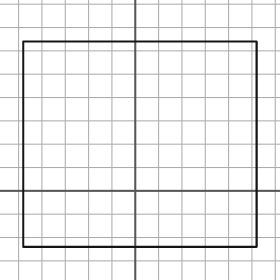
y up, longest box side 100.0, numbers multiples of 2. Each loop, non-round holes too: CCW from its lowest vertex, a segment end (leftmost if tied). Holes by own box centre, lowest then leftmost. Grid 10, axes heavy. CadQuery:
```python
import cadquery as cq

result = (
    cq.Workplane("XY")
    .moveTo(-48.0, -24.0)
    .lineTo(52.0, -24.0)
    .lineTo(52.0, 64.0)
    .lineTo(-48.0, 64.0)
    .close()
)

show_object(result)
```